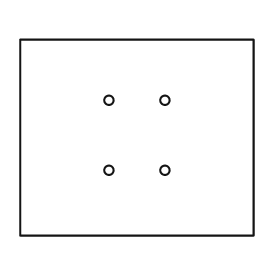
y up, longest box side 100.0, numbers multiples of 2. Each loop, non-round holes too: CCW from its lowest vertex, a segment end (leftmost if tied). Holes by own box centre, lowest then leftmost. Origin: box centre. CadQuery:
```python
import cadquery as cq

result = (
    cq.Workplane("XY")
    .moveTo(-50.0, -42.0)
    .lineTo(50.0, -42.0)
    .lineTo(50.0, 42.0)
    .lineTo(-50.0, 42.0)
    .close()
    .moveTo(-12.0, -14.0)
    .circle(2.0)
    .moveTo(12.0, -14.0)
    .circle(2.0)
    .moveTo(-12.0, 16.0)
    .circle(2.0)
    .moveTo(12.0, 16.0)
    .circle(2.0)
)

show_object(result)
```